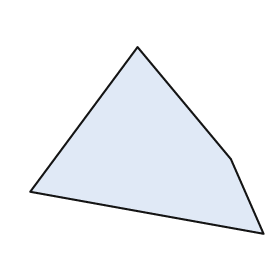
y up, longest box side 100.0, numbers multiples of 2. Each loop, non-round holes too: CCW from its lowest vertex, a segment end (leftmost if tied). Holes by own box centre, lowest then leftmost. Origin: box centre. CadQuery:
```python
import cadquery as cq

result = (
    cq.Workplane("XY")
    .moveTo(50.0, -40.0)
    .lineTo(36.0, -8.0)
    .lineTo(-4.0, 40.0)
    .lineTo(-50.0, -22.0)
    .close()
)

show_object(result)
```